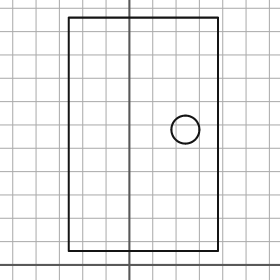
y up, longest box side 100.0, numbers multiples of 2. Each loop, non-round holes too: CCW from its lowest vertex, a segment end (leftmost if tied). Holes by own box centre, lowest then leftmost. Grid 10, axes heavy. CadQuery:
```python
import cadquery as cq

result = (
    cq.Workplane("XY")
    .moveTo(-26.0, 6.0)
    .lineTo(38.0, 6.0)
    .lineTo(38.0, 106.0)
    .lineTo(-26.0, 106.0)
    .close()
    .moveTo(24.0, 58.0)
    .circle(6.0)
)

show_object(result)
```